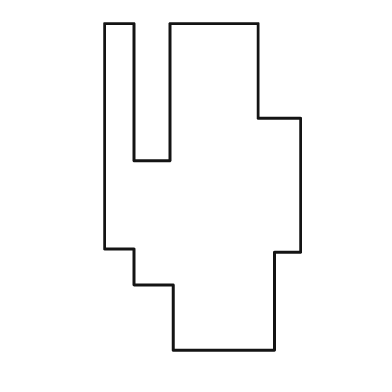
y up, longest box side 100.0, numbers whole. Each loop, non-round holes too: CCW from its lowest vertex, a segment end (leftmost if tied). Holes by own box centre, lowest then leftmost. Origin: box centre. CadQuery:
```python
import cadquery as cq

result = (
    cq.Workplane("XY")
    .moveTo(-9.0, -50.0)
    .lineTo(22.0, -50.0)
    .lineTo(22.0, -20.0)
    .lineTo(30.0, -20.0)
    .lineTo(30.0, 21.0)
    .lineTo(17.0, 21.0)
    .lineTo(17.0, 50.0)
    .lineTo(-10.0, 50.0)
    .lineTo(-10.0, 8.0)
    .lineTo(-21.0, 8.0)
    .lineTo(-21.0, 50.0)
    .lineTo(-30.0, 50.0)
    .lineTo(-30.0, -19.0)
    .lineTo(-21.0, -19.0)
    .lineTo(-21.0, -30.0)
    .lineTo(-9.0, -30.0)
    .close()
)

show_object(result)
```